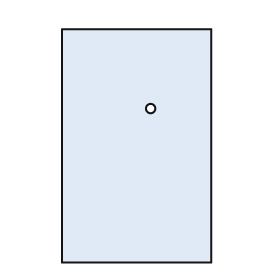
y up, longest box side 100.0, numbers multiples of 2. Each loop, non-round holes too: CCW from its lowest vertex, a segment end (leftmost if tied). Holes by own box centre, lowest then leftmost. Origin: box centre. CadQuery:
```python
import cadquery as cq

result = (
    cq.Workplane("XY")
    .moveTo(-32.0, -50.0)
    .lineTo(32.0, -50.0)
    .lineTo(32.0, 50.0)
    .lineTo(-32.0, 50.0)
    .close()
    .moveTo(6.0, 16.0)
    .circle(2.0)
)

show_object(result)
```